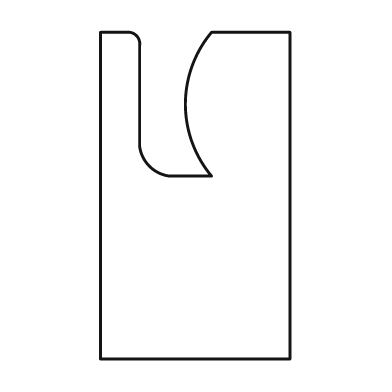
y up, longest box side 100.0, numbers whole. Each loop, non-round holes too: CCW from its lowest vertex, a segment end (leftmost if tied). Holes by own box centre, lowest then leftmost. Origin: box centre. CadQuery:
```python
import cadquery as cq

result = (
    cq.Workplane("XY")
    .moveTo(-29.0, -50.0)
    .lineTo(29.0, -50.0)
    .lineTo(29.0, 50.0)
    .lineTo(5.0, 50.0)
    .threePointArc((-3.0, 28.0), (5.0, 6.0))
    .lineTo(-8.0, 6.0)
    .threePointArc((-14.0, 9.0), (-17.0, 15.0))
    .lineTo(-17.0, 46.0)
    .threePointArc((-18.0, 49.0), (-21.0, 50.0))
    .lineTo(-29.0, 50.0)
    .close()
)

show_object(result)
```